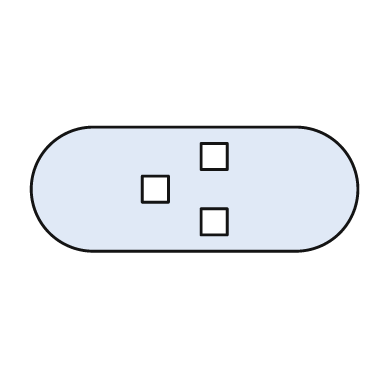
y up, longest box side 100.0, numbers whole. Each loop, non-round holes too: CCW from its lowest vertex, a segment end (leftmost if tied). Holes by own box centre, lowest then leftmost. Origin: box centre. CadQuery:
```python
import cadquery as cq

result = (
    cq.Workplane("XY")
    .moveTo(-31.0, -19.0)
    .lineTo(31.0, -19.0)
    .threePointArc((50.0, 0.0), (31.0, 19.0))
    .lineTo(-31.0, 19.0)
    .threePointArc((-50.0, 0.0), (-31.0, -19.0))
    .close()
    .moveTo(2.0, -14.0)
    .lineTo(10.0, -14.0)
    .lineTo(10.0, -6.0)
    .lineTo(2.0, -6.0)
    .close()
    .moveTo(-16.0, -4.0)
    .lineTo(-8.0, -4.0)
    .lineTo(-8.0, 4.0)
    .lineTo(-16.0, 4.0)
    .close()
    .moveTo(2.0, 6.0)
    .lineTo(10.0, 6.0)
    .lineTo(10.0, 14.0)
    .lineTo(2.0, 14.0)
    .close()
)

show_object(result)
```